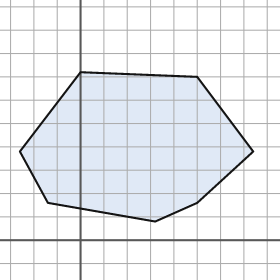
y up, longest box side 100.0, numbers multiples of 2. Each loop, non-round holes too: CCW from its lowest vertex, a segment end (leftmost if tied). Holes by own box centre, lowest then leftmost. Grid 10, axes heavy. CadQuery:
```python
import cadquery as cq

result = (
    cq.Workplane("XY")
    .moveTo(32.0, 8.0)
    .lineTo(50.0, 16.0)
    .lineTo(74.0, 38.0)
    .lineTo(50.0, 70.0)
    .lineTo(0.0, 72.0)
    .lineTo(-26.0, 38.0)
    .lineTo(-14.0, 16.0)
    .close()
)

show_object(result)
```